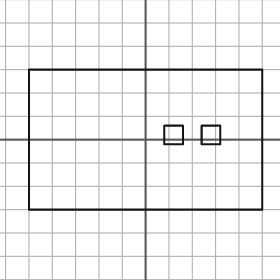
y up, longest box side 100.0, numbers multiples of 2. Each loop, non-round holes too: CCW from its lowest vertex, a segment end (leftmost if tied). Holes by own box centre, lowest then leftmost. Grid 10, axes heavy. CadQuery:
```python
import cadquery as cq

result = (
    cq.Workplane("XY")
    .moveTo(-50.0, -30.0)
    .lineTo(50.0, -30.0)
    .lineTo(50.0, 30.0)
    .lineTo(-50.0, 30.0)
    .close()
    .moveTo(8.0, -2.0)
    .lineTo(16.0, -2.0)
    .lineTo(16.0, 6.0)
    .lineTo(8.0, 6.0)
    .close()
    .moveTo(24.0, -2.0)
    .lineTo(32.0, -2.0)
    .lineTo(32.0, 6.0)
    .lineTo(24.0, 6.0)
    .close()
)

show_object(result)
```